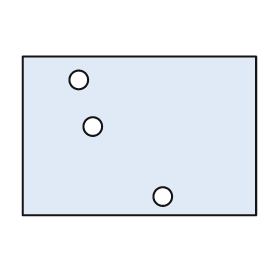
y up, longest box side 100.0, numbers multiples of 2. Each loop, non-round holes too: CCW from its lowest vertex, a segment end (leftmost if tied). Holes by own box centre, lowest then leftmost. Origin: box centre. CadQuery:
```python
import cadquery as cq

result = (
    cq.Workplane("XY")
    .moveTo(-50.0, -34.0)
    .lineTo(50.0, -34.0)
    .lineTo(50.0, 34.0)
    .lineTo(-50.0, 34.0)
    .close()
    .moveTo(10.0, -26.0)
    .circle(4.0)
    .moveTo(-20.0, 4.0)
    .circle(4.0)
    .moveTo(-26.0, 24.0)
    .circle(4.0)
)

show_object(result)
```